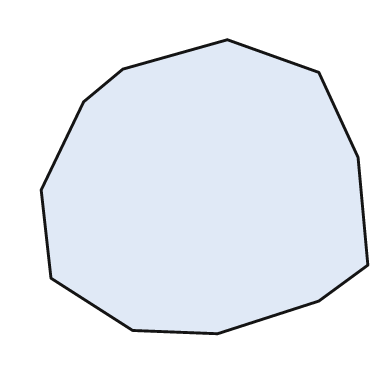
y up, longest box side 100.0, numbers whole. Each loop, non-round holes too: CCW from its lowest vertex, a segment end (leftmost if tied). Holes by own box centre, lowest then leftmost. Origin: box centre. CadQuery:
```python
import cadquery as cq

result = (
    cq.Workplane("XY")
    .moveTo(4.0, -45.0)
    .lineTo(35.0, -35.0)
    .lineTo(50.0, -24.0)
    .lineTo(47.0, 9.0)
    .lineTo(35.0, 35.0)
    .lineTo(7.0, 45.0)
    .lineTo(-25.0, 36.0)
    .lineTo(-37.0, 26.0)
    .lineTo(-50.0, -1.0)
    .lineTo(-47.0, -28.0)
    .lineTo(-22.0, -44.0)
    .close()
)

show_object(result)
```